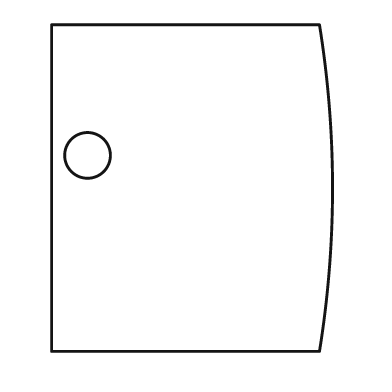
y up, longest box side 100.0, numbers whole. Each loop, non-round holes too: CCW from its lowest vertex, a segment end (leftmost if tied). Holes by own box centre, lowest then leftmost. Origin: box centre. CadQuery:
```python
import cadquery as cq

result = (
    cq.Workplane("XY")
    .moveTo(-43.0, -50.0)
    .lineTo(39.0, -50.0)
    .threePointArc((43.0, 0.0), (39.0, 50.0))
    .lineTo(-43.0, 50.0)
    .close()
    .moveTo(-32.0, 10.0)
    .circle(7.0)
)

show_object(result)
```